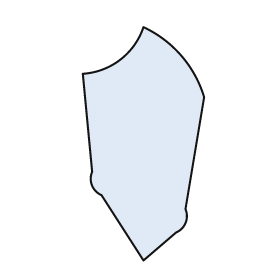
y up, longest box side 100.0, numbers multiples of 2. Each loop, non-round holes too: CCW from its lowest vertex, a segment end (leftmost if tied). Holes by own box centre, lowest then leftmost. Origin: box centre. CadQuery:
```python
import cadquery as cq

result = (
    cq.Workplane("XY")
    .moveTo(0.0, -50.0)
    .lineTo(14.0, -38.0)
    .threePointArc((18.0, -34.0), (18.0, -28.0))
    .lineTo(26.0, 20.0)
    .threePointArc((16.0, 38.0), (0.0, 50.0))
    .threePointArc((-10.0, 36.0), (-26.0, 30.0))
    .lineTo(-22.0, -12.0)
    .threePointArc((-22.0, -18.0), (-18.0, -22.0))
    .close()
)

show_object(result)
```